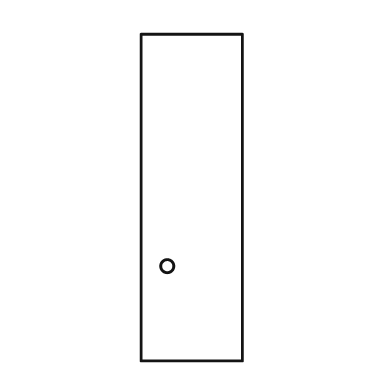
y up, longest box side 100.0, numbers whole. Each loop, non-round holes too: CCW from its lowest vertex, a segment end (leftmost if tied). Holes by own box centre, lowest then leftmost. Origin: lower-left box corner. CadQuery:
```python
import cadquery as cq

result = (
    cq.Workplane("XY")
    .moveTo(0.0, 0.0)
    .lineTo(31.0, 0.0)
    .lineTo(31.0, 100.0)
    .lineTo(0.0, 100.0)
    .close()
    .moveTo(8.0, 29.0)
    .circle(2.0)
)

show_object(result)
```